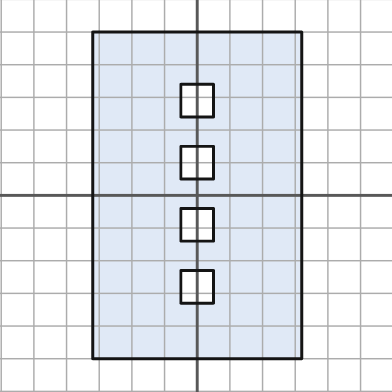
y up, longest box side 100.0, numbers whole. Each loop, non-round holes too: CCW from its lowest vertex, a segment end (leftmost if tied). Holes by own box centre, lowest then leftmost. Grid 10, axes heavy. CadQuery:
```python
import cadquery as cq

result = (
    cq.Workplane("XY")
    .moveTo(-32.0, -50.0)
    .lineTo(32.0, -50.0)
    .lineTo(32.0, 50.0)
    .lineTo(-32.0, 50.0)
    .close()
    .moveTo(-5.0, -33.0)
    .lineTo(5.0, -33.0)
    .lineTo(5.0, -23.0)
    .lineTo(-5.0, -23.0)
    .close()
    .moveTo(-5.0, -14.0)
    .lineTo(5.0, -14.0)
    .lineTo(5.0, -4.0)
    .lineTo(-5.0, -4.0)
    .close()
    .moveTo(-5.0, 5.0)
    .lineTo(5.0, 5.0)
    .lineTo(5.0, 15.0)
    .lineTo(-5.0, 15.0)
    .close()
    .moveTo(-5.0, 24.0)
    .lineTo(5.0, 24.0)
    .lineTo(5.0, 34.0)
    .lineTo(-5.0, 34.0)
    .close()
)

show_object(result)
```